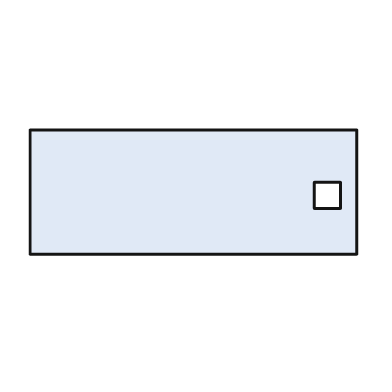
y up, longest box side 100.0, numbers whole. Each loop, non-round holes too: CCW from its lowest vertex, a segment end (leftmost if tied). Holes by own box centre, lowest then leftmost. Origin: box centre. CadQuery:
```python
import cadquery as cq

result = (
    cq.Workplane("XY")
    .moveTo(-50.0, -19.0)
    .lineTo(50.0, -19.0)
    .lineTo(50.0, 19.0)
    .lineTo(-50.0, 19.0)
    .close()
    .moveTo(37.0, -5.0)
    .lineTo(45.0, -5.0)
    .lineTo(45.0, 3.0)
    .lineTo(37.0, 3.0)
    .close()
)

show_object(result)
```